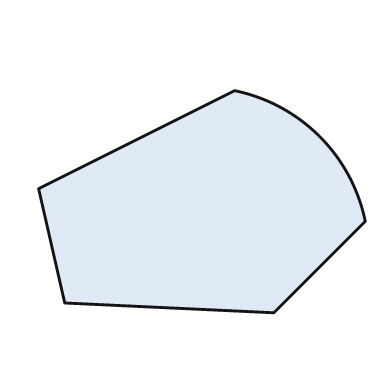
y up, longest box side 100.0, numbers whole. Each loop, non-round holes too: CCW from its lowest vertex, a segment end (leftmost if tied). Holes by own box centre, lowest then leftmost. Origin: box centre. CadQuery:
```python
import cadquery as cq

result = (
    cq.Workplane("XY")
    .moveTo(22.0, -34.0)
    .lineTo(50.0, -6.0)
    .threePointArc((36.0, 20.0), (10.0, 34.0))
    .lineTo(-50.0, 4.0)
    .lineTo(-42.0, -31.0)
    .close()
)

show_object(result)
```